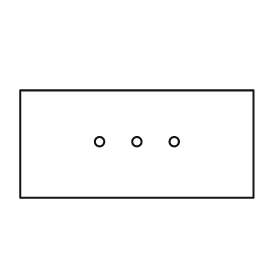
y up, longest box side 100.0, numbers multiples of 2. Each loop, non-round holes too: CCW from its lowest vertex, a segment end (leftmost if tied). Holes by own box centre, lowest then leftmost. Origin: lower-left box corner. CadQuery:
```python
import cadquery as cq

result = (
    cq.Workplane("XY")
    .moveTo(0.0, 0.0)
    .lineTo(100.0, 0.0)
    .lineTo(100.0, 46.0)
    .lineTo(0.0, 46.0)
    .close()
    .moveTo(34.0, 24.0)
    .circle(2.0)
    .moveTo(50.0, 24.0)
    .circle(2.0)
    .moveTo(66.0, 24.0)
    .circle(2.0)
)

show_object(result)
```